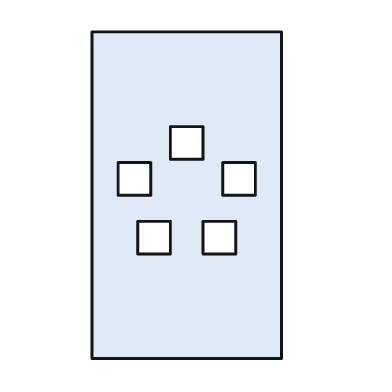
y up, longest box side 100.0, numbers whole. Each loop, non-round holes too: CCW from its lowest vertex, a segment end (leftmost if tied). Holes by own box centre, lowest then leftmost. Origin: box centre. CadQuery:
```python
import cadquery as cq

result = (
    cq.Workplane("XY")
    .moveTo(-29.0, -50.0)
    .lineTo(29.0, -50.0)
    .lineTo(29.0, 50.0)
    .lineTo(-29.0, 50.0)
    .close()
    .moveTo(-15.0, -18.0)
    .lineTo(-5.0, -18.0)
    .lineTo(-5.0, -8.0)
    .lineTo(-15.0, -8.0)
    .close()
    .moveTo(5.0, -18.0)
    .lineTo(15.0, -18.0)
    .lineTo(15.0, -8.0)
    .lineTo(5.0, -8.0)
    .close()
    .moveTo(-21.0, 0.0)
    .lineTo(-11.0, 0.0)
    .lineTo(-11.0, 10.0)
    .lineTo(-21.0, 10.0)
    .close()
    .moveTo(11.0, 0.0)
    .lineTo(21.0, 0.0)
    .lineTo(21.0, 10.0)
    .lineTo(11.0, 10.0)
    .close()
    .moveTo(-5.0, 11.0)
    .lineTo(5.0, 11.0)
    .lineTo(5.0, 21.0)
    .lineTo(-5.0, 21.0)
    .close()
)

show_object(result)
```